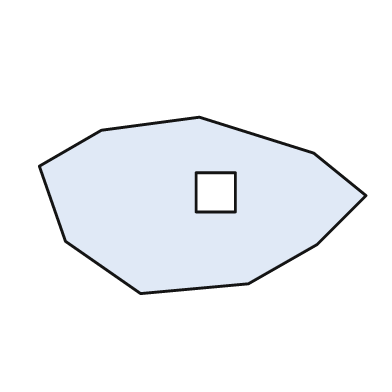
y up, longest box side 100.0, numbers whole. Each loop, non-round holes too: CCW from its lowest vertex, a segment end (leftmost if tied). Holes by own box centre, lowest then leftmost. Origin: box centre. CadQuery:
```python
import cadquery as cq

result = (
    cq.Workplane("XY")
    .moveTo(-19.0, -27.0)
    .lineTo(14.0, -24.0)
    .lineTo(35.0, -12.0)
    .lineTo(50.0, 3.0)
    .lineTo(34.0, 16.0)
    .lineTo(-1.0, 27.0)
    .lineTo(-31.0, 23.0)
    .lineTo(-50.0, 12.0)
    .lineTo(-42.0, -11.0)
    .close()
    .moveTo(-2.0, -2.0)
    .lineTo(10.0, -2.0)
    .lineTo(10.0, 10.0)
    .lineTo(-2.0, 10.0)
    .close()
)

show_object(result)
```